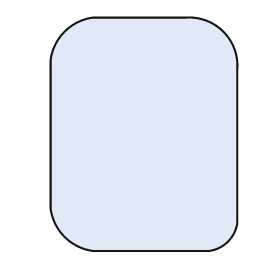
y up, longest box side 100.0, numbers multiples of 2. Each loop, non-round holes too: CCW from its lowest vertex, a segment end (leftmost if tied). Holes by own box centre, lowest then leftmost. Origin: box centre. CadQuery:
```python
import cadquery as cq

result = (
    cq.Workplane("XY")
    .moveTo(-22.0, -50.0)
    .lineTo(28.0, -50.0)
    .threePointArc((36.0, -46.0), (40.0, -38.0))
    .lineTo(40.0, 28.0)
    .threePointArc((34.0, 44.0), (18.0, 50.0))
    .lineTo(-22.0, 50.0)
    .threePointArc((-34.0, 44.0), (-40.0, 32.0))
    .lineTo(-40.0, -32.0)
    .threePointArc((-34.0, -44.0), (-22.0, -50.0))
    .close()
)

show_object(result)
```